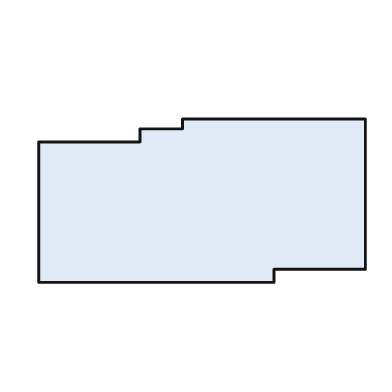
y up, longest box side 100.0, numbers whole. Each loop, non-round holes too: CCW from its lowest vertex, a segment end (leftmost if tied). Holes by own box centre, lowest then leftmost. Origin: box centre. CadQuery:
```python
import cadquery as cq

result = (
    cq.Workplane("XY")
    .moveTo(-50.0, -25.0)
    .lineTo(22.0, -25.0)
    .lineTo(22.0, -21.0)
    .lineTo(50.0, -21.0)
    .lineTo(50.0, 25.0)
    .lineTo(-6.0, 25.0)
    .lineTo(-6.0, 22.0)
    .lineTo(-19.0, 22.0)
    .lineTo(-19.0, 18.0)
    .lineTo(-50.0, 18.0)
    .close()
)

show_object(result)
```